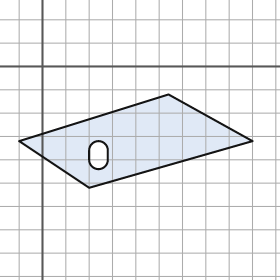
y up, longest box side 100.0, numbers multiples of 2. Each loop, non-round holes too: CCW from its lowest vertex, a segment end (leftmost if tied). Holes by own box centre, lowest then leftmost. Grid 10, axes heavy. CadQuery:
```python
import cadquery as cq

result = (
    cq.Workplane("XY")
    .moveTo(20.0, -52.0)
    .lineTo(90.0, -32.0)
    .lineTo(54.0, -12.0)
    .lineTo(-10.0, -32.0)
    .close()
    .moveTo(20.0, -40.0)
    .threePointArc((24.0, -44.0), (28.0, -40.0))
    .lineTo(28.0, -36.0)
    .threePointArc((24.0, -32.0), (20.0, -36.0))
    .close()
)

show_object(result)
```